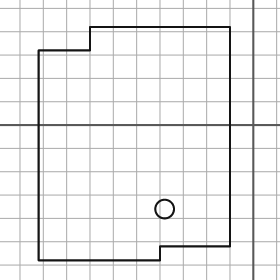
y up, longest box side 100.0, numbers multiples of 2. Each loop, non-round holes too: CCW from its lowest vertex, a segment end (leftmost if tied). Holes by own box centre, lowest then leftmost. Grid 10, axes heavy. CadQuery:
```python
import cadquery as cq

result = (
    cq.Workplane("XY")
    .moveTo(-92.0, -58.0)
    .lineTo(-40.0, -58.0)
    .lineTo(-40.0, -52.0)
    .lineTo(-10.0, -52.0)
    .lineTo(-10.0, 42.0)
    .lineTo(-70.0, 42.0)
    .lineTo(-70.0, 32.0)
    .lineTo(-92.0, 32.0)
    .close()
    .moveTo(-38.0, -36.0)
    .circle(4.0)
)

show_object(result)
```